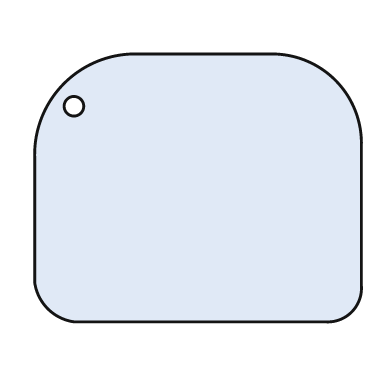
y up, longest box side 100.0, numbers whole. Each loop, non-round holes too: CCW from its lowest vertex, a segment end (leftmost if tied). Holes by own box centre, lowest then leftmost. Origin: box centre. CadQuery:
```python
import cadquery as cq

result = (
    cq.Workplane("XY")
    .moveTo(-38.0, -41.0)
    .lineTo(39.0, -41.0)
    .threePointArc((47.0, -38.0), (50.0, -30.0))
    .lineTo(50.0, 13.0)
    .threePointArc((42.0, 33.0), (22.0, 41.0))
    .lineTo(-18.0, 41.0)
    .threePointArc((-41.0, 32.0), (-50.0, 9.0))
    .lineTo(-50.0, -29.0)
    .threePointArc((-46.0, -37.0), (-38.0, -41.0))
    .close()
    .moveTo(-38.0, 25.0)
    .circle(3.0)
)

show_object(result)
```